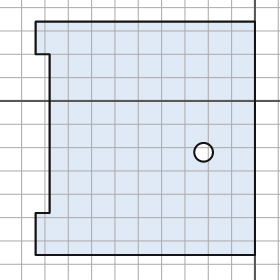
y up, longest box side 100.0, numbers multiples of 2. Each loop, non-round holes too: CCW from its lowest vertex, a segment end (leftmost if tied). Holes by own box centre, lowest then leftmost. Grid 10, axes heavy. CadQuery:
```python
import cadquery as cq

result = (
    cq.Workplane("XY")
    .moveTo(-94.0, -66.0)
    .lineTo(0.0, -66.0)
    .lineTo(0.0, 34.0)
    .lineTo(-94.0, 34.0)
    .lineTo(-94.0, 20.0)
    .lineTo(-88.0, 20.0)
    .lineTo(-88.0, -48.0)
    .lineTo(-94.0, -48.0)
    .close()
    .moveTo(-22.0, -22.0)
    .circle(4.0)
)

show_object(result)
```